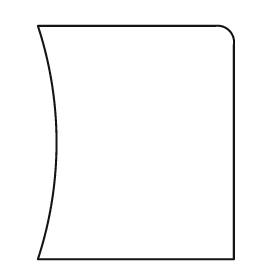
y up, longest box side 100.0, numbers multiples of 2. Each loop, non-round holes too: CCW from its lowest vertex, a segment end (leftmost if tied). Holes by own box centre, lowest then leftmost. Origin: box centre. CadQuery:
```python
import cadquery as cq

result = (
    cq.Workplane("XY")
    .moveTo(-42.0, -50.0)
    .lineTo(42.0, -50.0)
    .lineTo(42.0, 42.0)
    .threePointArc((40.0, 48.0), (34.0, 50.0))
    .lineTo(-42.0, 50.0)
    .threePointArc((-34.0, 0.0), (-42.0, -50.0))
    .close()
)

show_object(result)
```